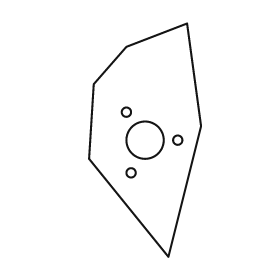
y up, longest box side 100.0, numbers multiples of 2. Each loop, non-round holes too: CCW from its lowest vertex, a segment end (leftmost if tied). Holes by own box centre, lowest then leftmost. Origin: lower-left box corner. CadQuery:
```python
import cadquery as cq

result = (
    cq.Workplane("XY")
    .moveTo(34.0, 0.0)
    .lineTo(48.0, 56.0)
    .lineTo(42.0, 100.0)
    .lineTo(16.0, 90.0)
    .lineTo(2.0, 74.0)
    .lineTo(0.0, 42.0)
    .close()
    .moveTo(18.0, 36.0)
    .circle(2.0)
    .moveTo(24.0, 50.0)
    .circle(8.0)
    .moveTo(38.0, 50.0)
    .circle(2.0)
    .moveTo(16.0, 62.0)
    .circle(2.0)
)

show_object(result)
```